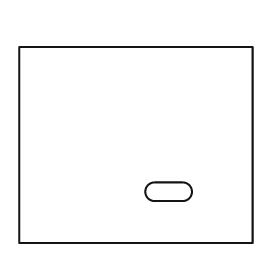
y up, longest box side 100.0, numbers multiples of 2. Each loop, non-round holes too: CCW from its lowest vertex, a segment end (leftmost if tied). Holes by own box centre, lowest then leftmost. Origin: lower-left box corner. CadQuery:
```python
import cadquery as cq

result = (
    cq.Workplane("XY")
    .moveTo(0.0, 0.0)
    .lineTo(100.0, 0.0)
    .lineTo(100.0, 84.0)
    .lineTo(0.0, 84.0)
    .close()
    .moveTo(58.0, 18.0)
    .lineTo(70.0, 18.0)
    .threePointArc((74.0, 22.0), (70.0, 26.0))
    .lineTo(58.0, 26.0)
    .threePointArc((54.0, 22.0), (58.0, 18.0))
    .close()
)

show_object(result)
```